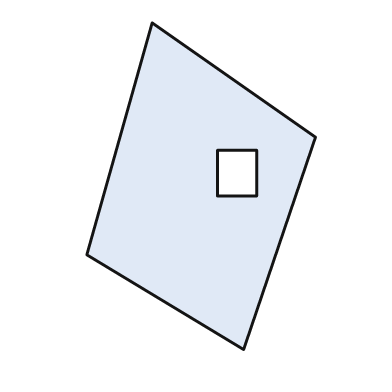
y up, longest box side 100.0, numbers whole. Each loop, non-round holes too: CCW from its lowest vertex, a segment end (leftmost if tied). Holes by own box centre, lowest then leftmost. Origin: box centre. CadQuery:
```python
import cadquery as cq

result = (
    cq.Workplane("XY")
    .moveTo(13.0, -50.0)
    .lineTo(35.0, 15.0)
    .lineTo(-15.0, 50.0)
    .lineTo(-35.0, -21.0)
    .close()
    .moveTo(5.0, -3.0)
    .lineTo(17.0, -3.0)
    .lineTo(17.0, 11.0)
    .lineTo(5.0, 11.0)
    .close()
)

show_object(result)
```